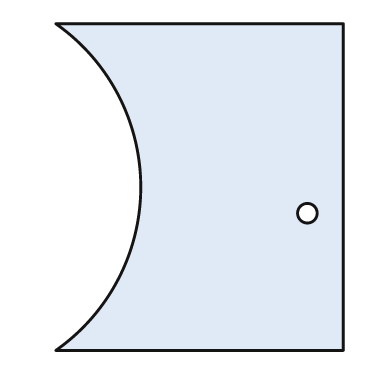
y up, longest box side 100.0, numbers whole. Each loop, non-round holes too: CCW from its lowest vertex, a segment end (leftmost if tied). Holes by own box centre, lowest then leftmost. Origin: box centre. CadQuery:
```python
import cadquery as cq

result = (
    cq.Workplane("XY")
    .moveTo(-44.0, -50.0)
    .lineTo(44.0, -50.0)
    .lineTo(44.0, 50.0)
    .lineTo(-44.0, 50.0)
    .threePointArc((-18.0, 0.0), (-44.0, -50.0))
    .close()
    .moveTo(33.0, -8.0)
    .circle(3.0)
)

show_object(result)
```